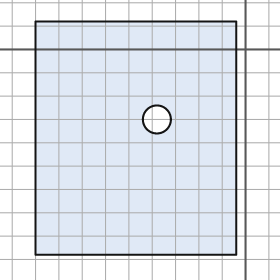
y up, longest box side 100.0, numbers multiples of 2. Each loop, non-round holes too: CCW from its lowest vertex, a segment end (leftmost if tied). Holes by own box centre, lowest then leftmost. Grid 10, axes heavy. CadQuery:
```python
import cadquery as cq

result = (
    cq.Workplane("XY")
    .moveTo(-90.0, -88.0)
    .lineTo(-4.0, -88.0)
    .lineTo(-4.0, 12.0)
    .lineTo(-90.0, 12.0)
    .close()
    .moveTo(-38.0, -30.0)
    .circle(6.0)
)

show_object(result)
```